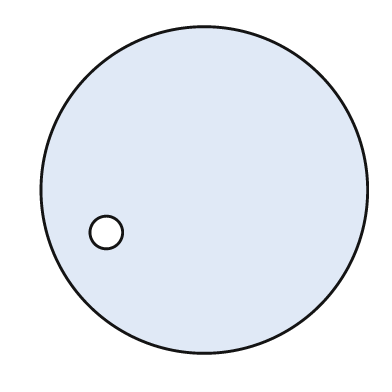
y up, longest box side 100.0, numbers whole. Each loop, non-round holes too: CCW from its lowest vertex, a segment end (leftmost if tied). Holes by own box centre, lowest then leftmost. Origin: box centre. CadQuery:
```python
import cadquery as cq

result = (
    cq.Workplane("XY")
    .moveTo(0.0, 0.0)
    .circle(50.0)
    .moveTo(-30.0, -13.0)
    .circle(5.0)
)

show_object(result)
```